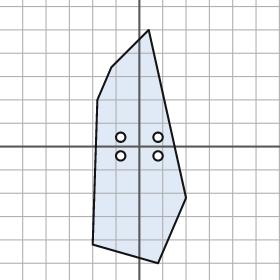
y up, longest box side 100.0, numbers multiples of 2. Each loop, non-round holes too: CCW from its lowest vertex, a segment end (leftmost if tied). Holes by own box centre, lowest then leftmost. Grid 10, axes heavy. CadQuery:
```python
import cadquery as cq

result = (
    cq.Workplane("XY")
    .moveTo(8.0, -50.0)
    .lineTo(20.0, -22.0)
    .lineTo(4.0, 50.0)
    .lineTo(-12.0, 34.0)
    .lineTo(-18.0, 20.0)
    .lineTo(-20.0, -42.0)
    .close()
    .moveTo(-8.0, -4.0)
    .circle(2.0)
    .moveTo(8.0, -4.0)
    .circle(2.0)
    .moveTo(-8.0, 4.0)
    .circle(2.0)
    .moveTo(8.0, 4.0)
    .circle(2.0)
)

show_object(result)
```